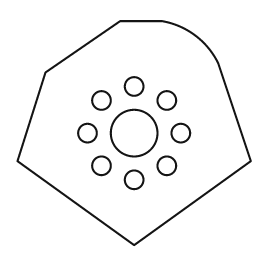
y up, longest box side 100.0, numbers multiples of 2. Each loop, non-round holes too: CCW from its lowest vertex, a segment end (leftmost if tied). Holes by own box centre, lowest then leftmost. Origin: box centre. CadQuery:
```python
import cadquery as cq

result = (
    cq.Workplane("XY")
    .moveTo(0.0, -48.0)
    .lineTo(50.0, -12.0)
    .lineTo(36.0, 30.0)
    .threePointArc((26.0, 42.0), (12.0, 48.0))
    .lineTo(-6.0, 48.0)
    .lineTo(-38.0, 26.0)
    .lineTo(-50.0, -12.0)
    .close()
    .moveTo(0.0, -20.0)
    .circle(4.0)
    .moveTo(-14.0, -14.0)
    .circle(4.0)
    .moveTo(14.0, -14.0)
    .circle(4.0)
    .moveTo(-20.0, 0.0)
    .circle(4.0)
    .moveTo(0.0, 0.0)
    .circle(10.0)
    .moveTo(20.0, 0.0)
    .circle(4.0)
    .moveTo(-14.0, 14.0)
    .circle(4.0)
    .moveTo(14.0, 14.0)
    .circle(4.0)
    .moveTo(0.0, 20.0)
    .circle(4.0)
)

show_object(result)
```